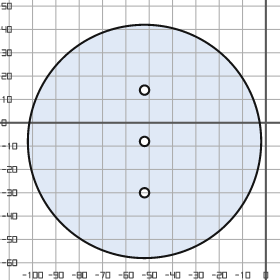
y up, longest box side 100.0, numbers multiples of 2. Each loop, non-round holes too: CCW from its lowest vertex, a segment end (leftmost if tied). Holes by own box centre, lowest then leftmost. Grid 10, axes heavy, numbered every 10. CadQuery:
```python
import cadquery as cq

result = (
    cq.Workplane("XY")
    .moveTo(-52.0, -8.0)
    .circle(50.0)
    .moveTo(-52.0, -30.0)
    .circle(2.0)
    .moveTo(-52.0, -8.0)
    .circle(2.0)
    .moveTo(-52.0, 14.0)
    .circle(2.0)
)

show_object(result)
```